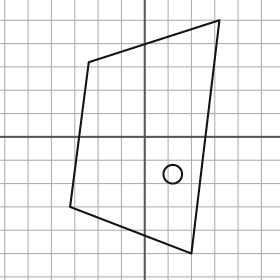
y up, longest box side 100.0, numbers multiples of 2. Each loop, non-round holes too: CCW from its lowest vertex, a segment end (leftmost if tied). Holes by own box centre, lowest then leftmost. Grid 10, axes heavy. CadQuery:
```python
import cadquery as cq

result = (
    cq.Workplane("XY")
    .moveTo(20.0, -50.0)
    .lineTo(32.0, 50.0)
    .lineTo(-24.0, 32.0)
    .lineTo(-32.0, -30.0)
    .close()
    .moveTo(12.0, -16.0)
    .circle(4.0)
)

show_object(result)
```